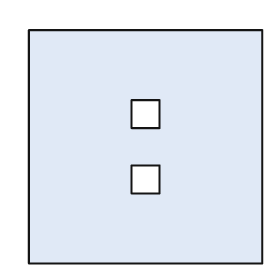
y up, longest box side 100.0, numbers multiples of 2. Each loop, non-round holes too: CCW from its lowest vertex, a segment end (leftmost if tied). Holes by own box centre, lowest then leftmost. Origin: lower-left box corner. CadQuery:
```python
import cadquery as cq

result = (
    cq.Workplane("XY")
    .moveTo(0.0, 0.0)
    .lineTo(100.0, 0.0)
    .lineTo(100.0, 100.0)
    .lineTo(0.0, 100.0)
    .close()
    .moveTo(44.0, 30.0)
    .lineTo(56.0, 30.0)
    .lineTo(56.0, 42.0)
    .lineTo(44.0, 42.0)
    .close()
    .moveTo(44.0, 58.0)
    .lineTo(56.0, 58.0)
    .lineTo(56.0, 70.0)
    .lineTo(44.0, 70.0)
    .close()
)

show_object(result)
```